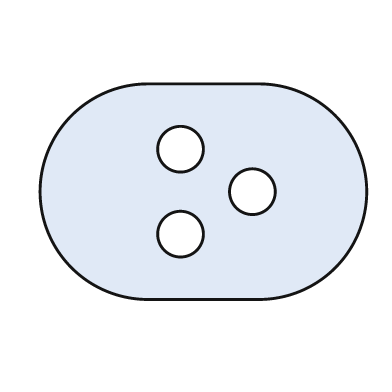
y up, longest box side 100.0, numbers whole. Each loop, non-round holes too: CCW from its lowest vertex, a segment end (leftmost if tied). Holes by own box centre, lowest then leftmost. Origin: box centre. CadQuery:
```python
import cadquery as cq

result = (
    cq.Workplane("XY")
    .moveTo(-17.0, -33.0)
    .lineTo(17.0, -33.0)
    .threePointArc((50.0, 0.0), (17.0, 33.0))
    .lineTo(-17.0, 33.0)
    .threePointArc((-50.0, 0.0), (-17.0, -33.0))
    .close()
    .moveTo(-7.0, -13.0)
    .circle(7.0)
    .moveTo(15.0, 0.0)
    .circle(7.0)
    .moveTo(-7.0, 13.0)
    .circle(7.0)
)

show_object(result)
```